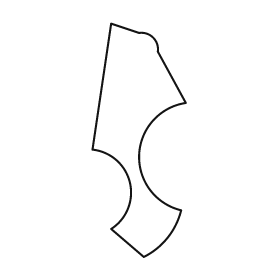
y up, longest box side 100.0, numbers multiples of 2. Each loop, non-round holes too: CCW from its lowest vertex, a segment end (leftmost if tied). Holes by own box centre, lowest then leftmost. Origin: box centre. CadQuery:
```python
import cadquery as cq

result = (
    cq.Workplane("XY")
    .moveTo(2.0, -50.0)
    .threePointArc((12.0, -42.0), (18.0, -30.0))
    .threePointArc((0.0, -6.0), (20.0, 16.0))
    .lineTo(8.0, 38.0)
    .threePointArc((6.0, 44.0), (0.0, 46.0))
    .lineTo(-12.0, 50.0)
    .lineTo(-20.0, -4.0)
    .threePointArc((-4.0, -18.0), (-12.0, -38.0))
    .close()
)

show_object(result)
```